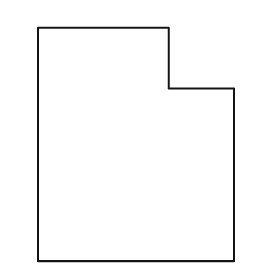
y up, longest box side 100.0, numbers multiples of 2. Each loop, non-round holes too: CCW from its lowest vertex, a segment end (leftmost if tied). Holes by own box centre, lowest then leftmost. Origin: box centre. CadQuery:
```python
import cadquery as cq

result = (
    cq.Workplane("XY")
    .moveTo(-42.0, -50.0)
    .lineTo(42.0, -50.0)
    .lineTo(42.0, 24.0)
    .lineTo(14.0, 24.0)
    .lineTo(14.0, 50.0)
    .lineTo(-42.0, 50.0)
    .close()
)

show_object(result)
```